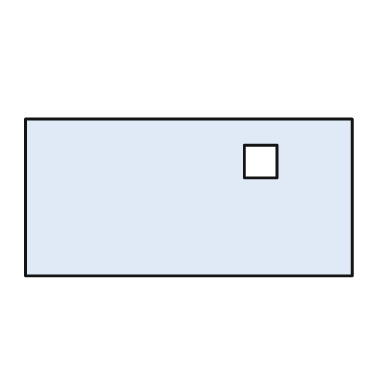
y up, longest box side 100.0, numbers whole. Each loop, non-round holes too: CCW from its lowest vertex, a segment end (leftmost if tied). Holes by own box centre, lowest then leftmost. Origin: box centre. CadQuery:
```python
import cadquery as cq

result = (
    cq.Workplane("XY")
    .moveTo(-50.0, -24.0)
    .lineTo(50.0, -24.0)
    .lineTo(50.0, 24.0)
    .lineTo(-50.0, 24.0)
    .close()
    .moveTo(17.0, 6.0)
    .lineTo(27.0, 6.0)
    .lineTo(27.0, 16.0)
    .lineTo(17.0, 16.0)
    .close()
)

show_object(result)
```